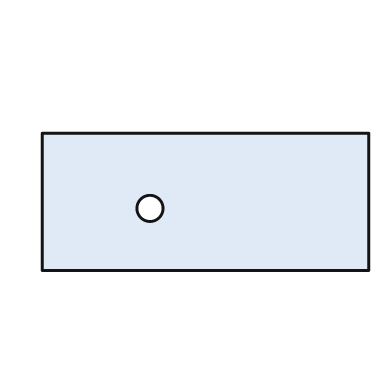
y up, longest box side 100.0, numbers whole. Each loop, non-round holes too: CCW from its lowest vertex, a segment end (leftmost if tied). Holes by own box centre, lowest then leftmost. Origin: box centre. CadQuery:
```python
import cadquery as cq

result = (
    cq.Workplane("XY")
    .moveTo(-50.0, -21.0)
    .lineTo(50.0, -21.0)
    .lineTo(50.0, 21.0)
    .lineTo(-50.0, 21.0)
    .close()
    .moveTo(-17.0, -2.0)
    .circle(4.0)
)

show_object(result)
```